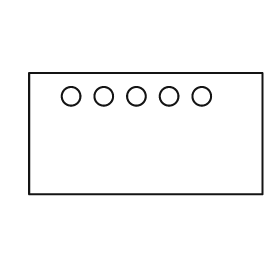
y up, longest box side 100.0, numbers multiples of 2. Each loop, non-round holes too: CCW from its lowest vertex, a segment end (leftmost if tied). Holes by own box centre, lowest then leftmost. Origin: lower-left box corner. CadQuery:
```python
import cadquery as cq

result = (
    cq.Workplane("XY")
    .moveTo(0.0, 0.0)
    .lineTo(100.0, 0.0)
    .lineTo(100.0, 52.0)
    .lineTo(0.0, 52.0)
    .close()
    .moveTo(18.0, 42.0)
    .circle(4.0)
    .moveTo(32.0, 42.0)
    .circle(4.0)
    .moveTo(46.0, 42.0)
    .circle(4.0)
    .moveTo(60.0, 42.0)
    .circle(4.0)
    .moveTo(74.0, 42.0)
    .circle(4.0)
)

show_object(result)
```